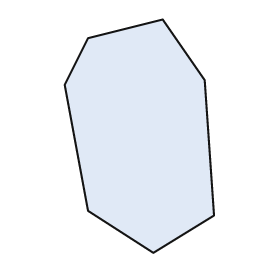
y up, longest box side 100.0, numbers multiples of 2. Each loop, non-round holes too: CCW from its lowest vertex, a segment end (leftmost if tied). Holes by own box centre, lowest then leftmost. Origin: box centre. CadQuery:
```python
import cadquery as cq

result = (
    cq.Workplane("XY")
    .moveTo(6.0, -50.0)
    .lineTo(32.0, -34.0)
    .lineTo(28.0, 24.0)
    .lineTo(10.0, 50.0)
    .lineTo(-22.0, 42.0)
    .lineTo(-32.0, 22.0)
    .lineTo(-22.0, -32.0)
    .close()
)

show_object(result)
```